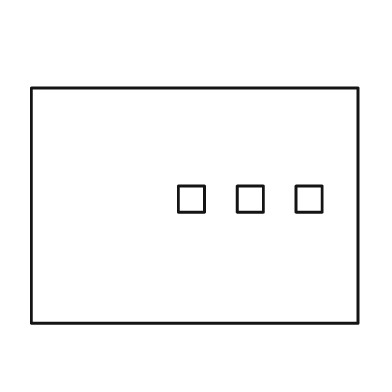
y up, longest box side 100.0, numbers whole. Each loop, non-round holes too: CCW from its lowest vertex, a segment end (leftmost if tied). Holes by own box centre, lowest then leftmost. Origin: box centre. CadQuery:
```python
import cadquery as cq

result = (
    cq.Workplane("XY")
    .moveTo(-50.0, -36.0)
    .lineTo(50.0, -36.0)
    .lineTo(50.0, 36.0)
    .lineTo(-50.0, 36.0)
    .close()
    .moveTo(-5.0, -2.0)
    .lineTo(3.0, -2.0)
    .lineTo(3.0, 6.0)
    .lineTo(-5.0, 6.0)
    .close()
    .moveTo(13.0, -2.0)
    .lineTo(21.0, -2.0)
    .lineTo(21.0, 6.0)
    .lineTo(13.0, 6.0)
    .close()
    .moveTo(31.0, -2.0)
    .lineTo(39.0, -2.0)
    .lineTo(39.0, 6.0)
    .lineTo(31.0, 6.0)
    .close()
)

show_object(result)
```